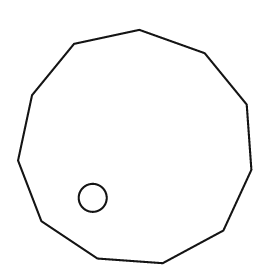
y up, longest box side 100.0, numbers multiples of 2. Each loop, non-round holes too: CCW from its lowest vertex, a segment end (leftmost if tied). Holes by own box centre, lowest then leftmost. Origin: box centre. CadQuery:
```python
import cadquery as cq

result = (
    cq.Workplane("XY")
    .moveTo(12.0, -50.0)
    .lineTo(38.0, -36.0)
    .lineTo(50.0, -10.0)
    .lineTo(48.0, 18.0)
    .lineTo(30.0, 40.0)
    .lineTo(2.0, 50.0)
    .lineTo(-26.0, 44.0)
    .lineTo(-44.0, 22.0)
    .lineTo(-50.0, -6.0)
    .lineTo(-40.0, -32.0)
    .lineTo(-16.0, -48.0)
    .close()
    .moveTo(-18.0, -22.0)
    .circle(6.0)
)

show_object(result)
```